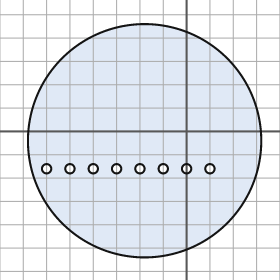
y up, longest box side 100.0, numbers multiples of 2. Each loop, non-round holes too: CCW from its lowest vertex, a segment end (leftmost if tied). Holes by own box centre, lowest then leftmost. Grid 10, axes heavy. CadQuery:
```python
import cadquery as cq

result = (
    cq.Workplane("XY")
    .moveTo(-18.0, -4.0)
    .circle(50.0)
    .moveTo(-60.0, -16.0)
    .circle(2.0)
    .moveTo(-50.0, -16.0)
    .circle(2.0)
    .moveTo(-40.0, -16.0)
    .circle(2.0)
    .moveTo(-30.0, -16.0)
    .circle(2.0)
    .moveTo(-20.0, -16.0)
    .circle(2.0)
    .moveTo(-10.0, -16.0)
    .circle(2.0)
    .moveTo(0.0, -16.0)
    .circle(2.0)
    .moveTo(10.0, -16.0)
    .circle(2.0)
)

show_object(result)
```